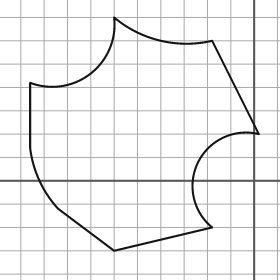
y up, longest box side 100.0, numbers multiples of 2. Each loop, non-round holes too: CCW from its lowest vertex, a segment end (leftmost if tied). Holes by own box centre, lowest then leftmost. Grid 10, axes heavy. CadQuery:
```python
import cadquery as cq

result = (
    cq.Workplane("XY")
    .moveTo(-60.0, -30.0)
    .lineTo(-18.0, -20.0)
    .threePointArc((-24.0, 8.0), (2.0, 20.0))
    .lineTo(-18.0, 60.0)
    .threePointArc((-40.0, 60.0), (-60.0, 70.0))
    .threePointArc((-70.0, 46.0), (-96.0, 42.0))
    .lineTo(-96.0, 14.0)
    .threePointArc((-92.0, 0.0), (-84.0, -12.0))
    .close()
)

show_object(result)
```